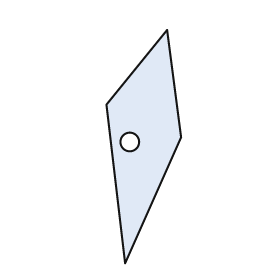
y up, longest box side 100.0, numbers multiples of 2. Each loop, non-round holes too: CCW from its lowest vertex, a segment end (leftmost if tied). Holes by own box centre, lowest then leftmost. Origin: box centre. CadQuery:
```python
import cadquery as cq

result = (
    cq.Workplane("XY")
    .moveTo(-8.0, -50.0)
    .lineTo(16.0, 4.0)
    .lineTo(10.0, 50.0)
    .lineTo(-16.0, 18.0)
    .close()
    .moveTo(-6.0, 2.0)
    .circle(4.0)
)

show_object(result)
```